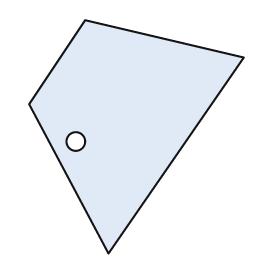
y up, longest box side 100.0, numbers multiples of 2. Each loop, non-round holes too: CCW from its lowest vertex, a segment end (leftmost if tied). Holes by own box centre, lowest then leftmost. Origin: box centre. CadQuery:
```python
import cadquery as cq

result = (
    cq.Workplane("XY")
    .moveTo(-12.0, -50.0)
    .lineTo(46.0, 34.0)
    .lineTo(-22.0, 50.0)
    .lineTo(-46.0, 14.0)
    .close()
    .moveTo(-26.0, -2.0)
    .circle(4.0)
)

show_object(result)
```